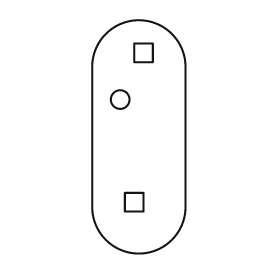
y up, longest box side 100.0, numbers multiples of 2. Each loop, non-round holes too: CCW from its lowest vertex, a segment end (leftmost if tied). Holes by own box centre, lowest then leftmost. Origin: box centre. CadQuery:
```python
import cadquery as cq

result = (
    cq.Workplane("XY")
    .moveTo(-20.0, -30.0)
    .threePointArc((0.0, -50.0), (20.0, -30.0))
    .lineTo(20.0, 30.0)
    .threePointArc((0.0, 50.0), (-20.0, 30.0))
    .close()
    .moveTo(-6.0, -32.0)
    .lineTo(2.0, -32.0)
    .lineTo(2.0, -24.0)
    .lineTo(-6.0, -24.0)
    .close()
    .moveTo(-8.0, 16.0)
    .circle(4.0)
    .moveTo(-2.0, 32.0)
    .lineTo(6.0, 32.0)
    .lineTo(6.0, 40.0)
    .lineTo(-2.0, 40.0)
    .close()
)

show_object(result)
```